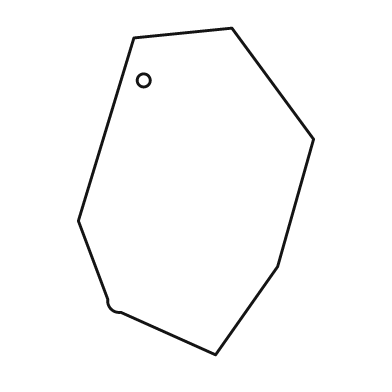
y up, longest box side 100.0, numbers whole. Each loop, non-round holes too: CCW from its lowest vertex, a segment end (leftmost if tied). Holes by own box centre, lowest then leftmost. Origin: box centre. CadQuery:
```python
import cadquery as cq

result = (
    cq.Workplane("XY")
    .moveTo(6.0, -50.0)
    .lineTo(25.0, -23.0)
    .lineTo(36.0, 16.0)
    .lineTo(11.0, 50.0)
    .lineTo(-19.0, 47.0)
    .lineTo(-36.0, -9.0)
    .lineTo(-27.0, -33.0)
    .threePointArc((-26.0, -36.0), (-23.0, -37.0))
    .close()
    .moveTo(-16.0, 34.0)
    .circle(2.0)
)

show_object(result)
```